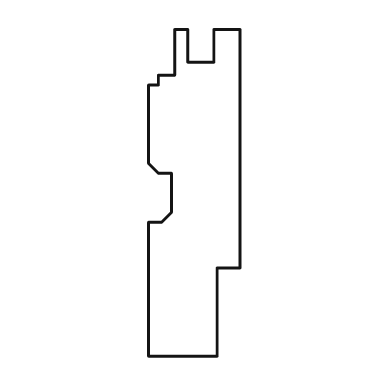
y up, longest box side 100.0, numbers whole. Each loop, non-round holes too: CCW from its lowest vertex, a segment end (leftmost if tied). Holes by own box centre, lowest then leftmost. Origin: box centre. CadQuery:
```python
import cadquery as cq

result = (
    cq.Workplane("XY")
    .moveTo(-14.0, -50.0)
    .lineTo(7.0, -50.0)
    .lineTo(7.0, -23.0)
    .lineTo(14.0, -23.0)
    .lineTo(14.0, 50.0)
    .lineTo(6.0, 50.0)
    .lineTo(6.0, 40.0)
    .lineTo(-2.0, 40.0)
    .lineTo(-2.0, 50.0)
    .lineTo(-6.0, 50.0)
    .lineTo(-6.0, 36.0)
    .lineTo(-11.0, 36.0)
    .lineTo(-11.0, 33.0)
    .lineTo(-14.0, 33.0)
    .lineTo(-14.0, 9.0)
    .lineTo(-11.0, 6.0)
    .lineTo(-7.0, 6.0)
    .lineTo(-7.0, -6.0)
    .lineTo(-10.0, -9.0)
    .lineTo(-14.0, -9.0)
    .close()
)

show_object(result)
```